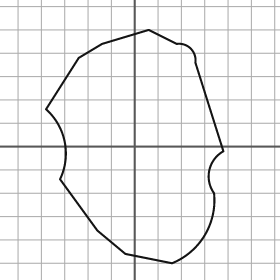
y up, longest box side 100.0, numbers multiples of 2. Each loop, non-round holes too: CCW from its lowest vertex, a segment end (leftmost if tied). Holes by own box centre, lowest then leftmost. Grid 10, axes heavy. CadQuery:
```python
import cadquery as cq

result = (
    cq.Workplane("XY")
    .moveTo(16.0, -50.0)
    .threePointArc((30.0, -38.0), (34.0, -20.0))
    .threePointArc((32.0, -10.0), (38.0, -2.0))
    .lineTo(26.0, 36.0)
    .threePointArc((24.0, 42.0), (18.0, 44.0))
    .lineTo(6.0, 50.0)
    .lineTo(-14.0, 44.0)
    .lineTo(-24.0, 38.0)
    .lineTo(-38.0, 16.0)
    .threePointArc((-30.0, 2.0), (-32.0, -14.0))
    .lineTo(-16.0, -36.0)
    .lineTo(-4.0, -46.0)
    .close()
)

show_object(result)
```